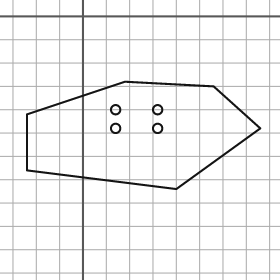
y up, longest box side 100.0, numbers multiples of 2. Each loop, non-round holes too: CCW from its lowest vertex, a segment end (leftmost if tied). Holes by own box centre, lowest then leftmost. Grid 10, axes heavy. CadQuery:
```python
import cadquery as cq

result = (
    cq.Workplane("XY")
    .moveTo(40.0, -74.0)
    .lineTo(76.0, -48.0)
    .lineTo(56.0, -30.0)
    .lineTo(18.0, -28.0)
    .lineTo(-24.0, -42.0)
    .lineTo(-24.0, -66.0)
    .close()
    .moveTo(14.0, -48.0)
    .circle(2.0)
    .moveTo(32.0, -48.0)
    .circle(2.0)
    .moveTo(14.0, -40.0)
    .circle(2.0)
    .moveTo(32.0, -40.0)
    .circle(2.0)
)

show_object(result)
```